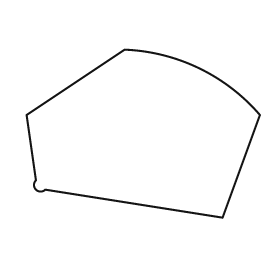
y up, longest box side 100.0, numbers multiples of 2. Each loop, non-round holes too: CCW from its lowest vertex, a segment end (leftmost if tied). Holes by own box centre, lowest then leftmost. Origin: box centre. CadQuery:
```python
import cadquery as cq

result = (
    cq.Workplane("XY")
    .moveTo(34.0, -36.0)
    .lineTo(50.0, 8.0)
    .threePointArc((24.0, 28.0), (-8.0, 36.0))
    .lineTo(-50.0, 8.0)
    .lineTo(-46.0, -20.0)
    .threePointArc((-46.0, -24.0), (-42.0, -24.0))
    .close()
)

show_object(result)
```